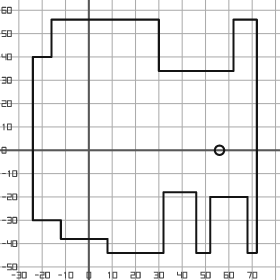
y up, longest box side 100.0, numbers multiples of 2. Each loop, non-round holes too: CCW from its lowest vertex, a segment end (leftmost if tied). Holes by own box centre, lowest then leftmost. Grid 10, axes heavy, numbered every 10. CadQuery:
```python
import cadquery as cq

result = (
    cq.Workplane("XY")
    .moveTo(8.0, -44.0)
    .lineTo(32.0, -44.0)
    .lineTo(32.0, -18.0)
    .lineTo(46.0, -18.0)
    .lineTo(46.0, -44.0)
    .lineTo(52.0, -44.0)
    .lineTo(52.0, -20.0)
    .lineTo(68.0, -20.0)
    .lineTo(68.0, -44.0)
    .lineTo(72.0, -44.0)
    .lineTo(72.0, 56.0)
    .lineTo(62.0, 56.0)
    .lineTo(62.0, 34.0)
    .lineTo(30.0, 34.0)
    .lineTo(30.0, 56.0)
    .lineTo(-16.0, 56.0)
    .lineTo(-16.0, 40.0)
    .lineTo(-24.0, 40.0)
    .lineTo(-24.0, -30.0)
    .lineTo(-12.0, -30.0)
    .lineTo(-12.0, -38.0)
    .lineTo(8.0, -38.0)
    .close()
    .moveTo(56.0, 0.0)
    .circle(2.0)
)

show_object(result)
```